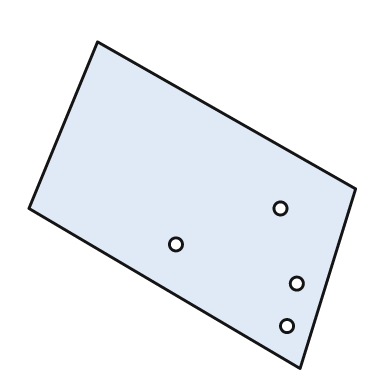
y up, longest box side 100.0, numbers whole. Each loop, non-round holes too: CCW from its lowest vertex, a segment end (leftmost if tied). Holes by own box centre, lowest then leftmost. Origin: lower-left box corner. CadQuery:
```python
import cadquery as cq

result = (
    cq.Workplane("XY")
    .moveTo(83.0, 0.0)
    .lineTo(100.0, 55.0)
    .lineTo(21.0, 100.0)
    .lineTo(0.0, 49.0)
    .close()
    .moveTo(79.0, 13.0)
    .circle(2.0)
    .moveTo(82.0, 26.0)
    .circle(2.0)
    .moveTo(45.0, 38.0)
    .circle(2.0)
    .moveTo(77.0, 49.0)
    .circle(2.0)
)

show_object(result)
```